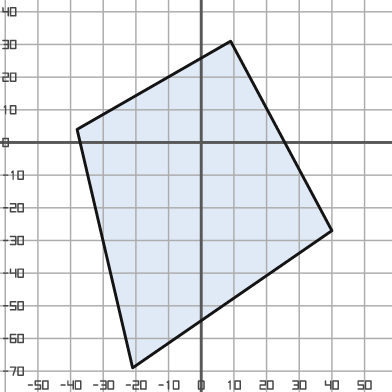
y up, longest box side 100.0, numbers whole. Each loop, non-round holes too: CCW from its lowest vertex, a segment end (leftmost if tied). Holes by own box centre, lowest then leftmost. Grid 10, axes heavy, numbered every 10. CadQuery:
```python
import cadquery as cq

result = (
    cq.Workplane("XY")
    .moveTo(-21.0, -69.0)
    .lineTo(40.0, -27.0)
    .lineTo(9.0, 31.0)
    .lineTo(-38.0, 4.0)
    .close()
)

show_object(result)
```